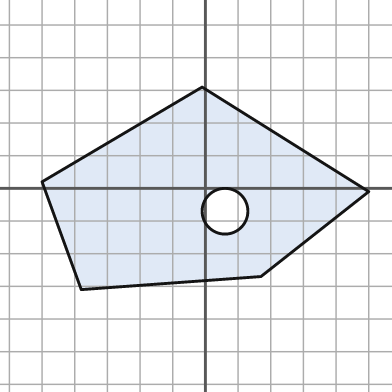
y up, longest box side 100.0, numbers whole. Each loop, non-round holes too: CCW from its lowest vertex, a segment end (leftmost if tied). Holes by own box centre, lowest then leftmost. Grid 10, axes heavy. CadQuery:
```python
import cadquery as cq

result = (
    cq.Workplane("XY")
    .moveTo(-38.0, -31.0)
    .lineTo(17.0, -27.0)
    .lineTo(50.0, -1.0)
    .lineTo(-1.0, 31.0)
    .lineTo(-50.0, 2.0)
    .close()
    .moveTo(6.0, -7.0)
    .circle(7.0)
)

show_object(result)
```